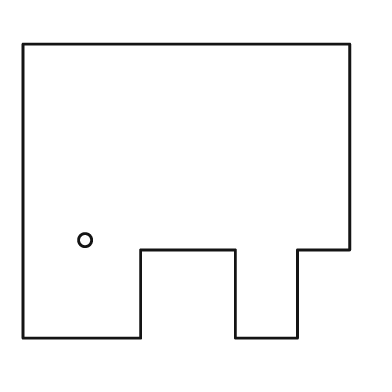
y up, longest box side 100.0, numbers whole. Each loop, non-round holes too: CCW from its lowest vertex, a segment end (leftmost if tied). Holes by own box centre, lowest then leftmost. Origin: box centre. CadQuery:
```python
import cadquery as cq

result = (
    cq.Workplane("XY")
    .moveTo(-50.0, -45.0)
    .lineTo(-14.0, -45.0)
    .lineTo(-14.0, -18.0)
    .lineTo(15.0, -18.0)
    .lineTo(15.0, -45.0)
    .lineTo(34.0, -45.0)
    .lineTo(34.0, -18.0)
    .lineTo(50.0, -18.0)
    .lineTo(50.0, 45.0)
    .lineTo(-50.0, 45.0)
    .close()
    .moveTo(-31.0, -15.0)
    .circle(2.0)
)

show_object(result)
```